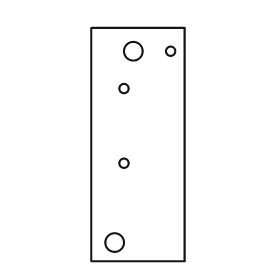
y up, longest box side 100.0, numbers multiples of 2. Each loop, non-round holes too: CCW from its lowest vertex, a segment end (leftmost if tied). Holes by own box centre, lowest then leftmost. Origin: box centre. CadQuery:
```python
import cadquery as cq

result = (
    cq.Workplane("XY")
    .moveTo(-20.0, -50.0)
    .lineTo(20.0, -50.0)
    .lineTo(20.0, 50.0)
    .lineTo(-20.0, 50.0)
    .close()
    .moveTo(-10.0, -42.0)
    .circle(4.0)
    .moveTo(-6.0, -8.0)
    .circle(2.0)
    .moveTo(-6.0, 24.0)
    .circle(2.0)
    .moveTo(-2.0, 40.0)
    .circle(4.0)
    .moveTo(14.0, 40.0)
    .circle(2.0)
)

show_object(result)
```